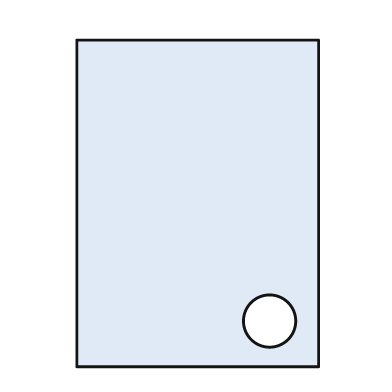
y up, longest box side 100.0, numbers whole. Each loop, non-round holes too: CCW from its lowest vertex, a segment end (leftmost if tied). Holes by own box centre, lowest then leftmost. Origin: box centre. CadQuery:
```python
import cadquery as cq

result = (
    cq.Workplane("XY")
    .moveTo(-37.0, -50.0)
    .lineTo(37.0, -50.0)
    .lineTo(37.0, 50.0)
    .lineTo(-37.0, 50.0)
    .close()
    .moveTo(22.0, -36.0)
    .circle(8.0)
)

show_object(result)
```